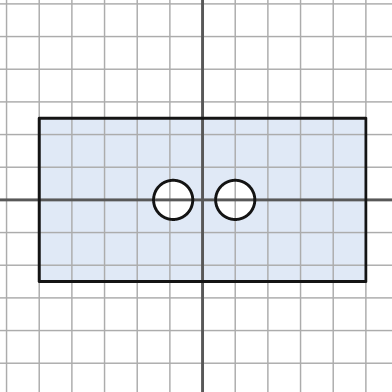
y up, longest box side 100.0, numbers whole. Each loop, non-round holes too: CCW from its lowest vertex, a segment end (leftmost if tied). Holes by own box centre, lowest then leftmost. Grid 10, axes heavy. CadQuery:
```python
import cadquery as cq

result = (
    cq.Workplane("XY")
    .moveTo(-50.0, -25.0)
    .lineTo(50.0, -25.0)
    .lineTo(50.0, 25.0)
    .lineTo(-50.0, 25.0)
    .close()
    .moveTo(-9.0, 0.0)
    .circle(6.0)
    .moveTo(10.0, 0.0)
    .circle(6.0)
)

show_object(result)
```